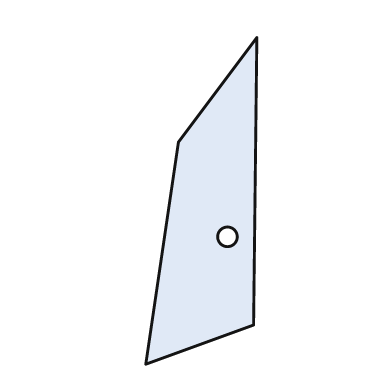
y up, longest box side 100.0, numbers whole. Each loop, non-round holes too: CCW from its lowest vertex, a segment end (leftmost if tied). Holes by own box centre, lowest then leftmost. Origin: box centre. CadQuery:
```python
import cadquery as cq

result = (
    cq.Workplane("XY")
    .moveTo(-17.0, -50.0)
    .lineTo(16.0, -38.0)
    .lineTo(17.0, 50.0)
    .lineTo(-7.0, 18.0)
    .close()
    .moveTo(8.0, -11.0)
    .circle(3.0)
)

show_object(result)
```